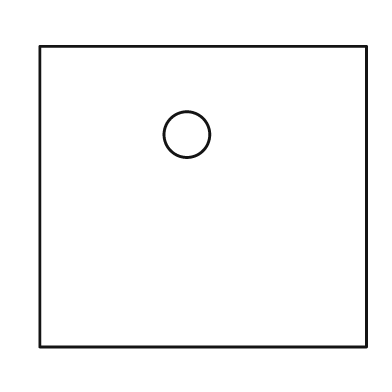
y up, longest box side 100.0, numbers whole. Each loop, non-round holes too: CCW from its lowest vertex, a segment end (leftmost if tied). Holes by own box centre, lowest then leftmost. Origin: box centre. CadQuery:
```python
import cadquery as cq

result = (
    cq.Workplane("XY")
    .moveTo(-50.0, -46.0)
    .lineTo(50.0, -46.0)
    .lineTo(50.0, 46.0)
    .lineTo(-50.0, 46.0)
    .close()
    .moveTo(-5.0, 19.0)
    .circle(7.0)
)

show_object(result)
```